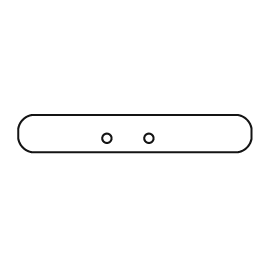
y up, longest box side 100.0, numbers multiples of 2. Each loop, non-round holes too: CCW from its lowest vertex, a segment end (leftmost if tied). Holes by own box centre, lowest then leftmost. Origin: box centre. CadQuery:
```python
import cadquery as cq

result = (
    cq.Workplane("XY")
    .moveTo(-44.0, -8.0)
    .lineTo(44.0, -8.0)
    .threePointArc((48.0, -6.0), (50.0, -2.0))
    .lineTo(50.0, 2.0)
    .threePointArc((48.0, 6.0), (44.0, 8.0))
    .lineTo(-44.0, 8.0)
    .threePointArc((-48.0, 6.0), (-50.0, 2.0))
    .lineTo(-50.0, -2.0)
    .threePointArc((-48.0, -6.0), (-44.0, -8.0))
    .close()
    .moveTo(-12.0, -2.0)
    .circle(2.0)
    .moveTo(6.0, -2.0)
    .circle(2.0)
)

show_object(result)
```